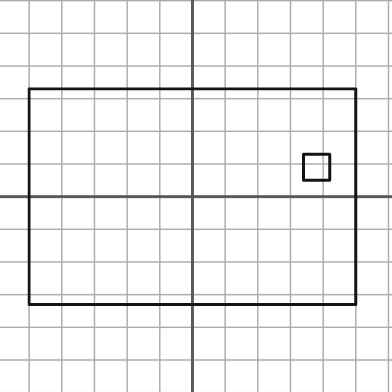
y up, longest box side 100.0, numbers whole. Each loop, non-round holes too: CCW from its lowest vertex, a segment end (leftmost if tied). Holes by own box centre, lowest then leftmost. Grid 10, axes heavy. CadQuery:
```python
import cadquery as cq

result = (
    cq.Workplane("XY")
    .moveTo(-50.0, -33.0)
    .lineTo(50.0, -33.0)
    .lineTo(50.0, 33.0)
    .lineTo(-50.0, 33.0)
    .close()
    .moveTo(34.0, 5.0)
    .lineTo(42.0, 5.0)
    .lineTo(42.0, 13.0)
    .lineTo(34.0, 13.0)
    .close()
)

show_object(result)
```